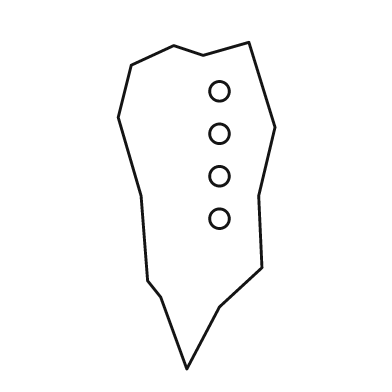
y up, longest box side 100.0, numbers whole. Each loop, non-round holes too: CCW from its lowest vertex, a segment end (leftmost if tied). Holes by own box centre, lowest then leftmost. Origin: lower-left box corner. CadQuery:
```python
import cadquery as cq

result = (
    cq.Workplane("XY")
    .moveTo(21.0, 0.0)
    .lineTo(31.0, 19.0)
    .lineTo(44.0, 31.0)
    .lineTo(43.0, 53.0)
    .lineTo(48.0, 74.0)
    .lineTo(40.0, 100.0)
    .lineTo(26.0, 96.0)
    .lineTo(17.0, 99.0)
    .lineTo(4.0, 93.0)
    .lineTo(0.0, 77.0)
    .lineTo(7.0, 53.0)
    .lineTo(9.0, 27.0)
    .lineTo(13.0, 22.0)
    .close()
    .moveTo(31.0, 46.0)
    .circle(3.0)
    .moveTo(31.0, 59.0)
    .circle(3.0)
    .moveTo(31.0, 72.0)
    .circle(3.0)
    .moveTo(31.0, 85.0)
    .circle(3.0)
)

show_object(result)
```